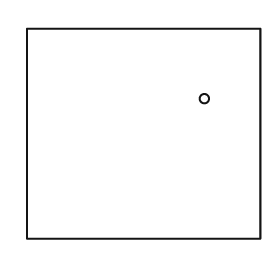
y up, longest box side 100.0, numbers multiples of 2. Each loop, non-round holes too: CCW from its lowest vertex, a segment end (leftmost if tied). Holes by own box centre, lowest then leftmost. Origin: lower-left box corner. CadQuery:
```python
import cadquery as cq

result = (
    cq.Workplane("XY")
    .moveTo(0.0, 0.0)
    .lineTo(100.0, 0.0)
    .lineTo(100.0, 90.0)
    .lineTo(0.0, 90.0)
    .close()
    .moveTo(76.0, 60.0)
    .circle(2.0)
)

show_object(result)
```